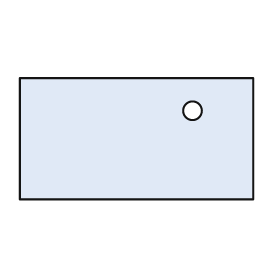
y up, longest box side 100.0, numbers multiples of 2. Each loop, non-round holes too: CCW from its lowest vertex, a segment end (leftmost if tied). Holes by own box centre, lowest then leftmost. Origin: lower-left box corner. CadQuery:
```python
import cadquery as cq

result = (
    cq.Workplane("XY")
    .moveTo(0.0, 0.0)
    .lineTo(100.0, 0.0)
    .lineTo(100.0, 52.0)
    .lineTo(0.0, 52.0)
    .close()
    .moveTo(74.0, 38.0)
    .circle(4.0)
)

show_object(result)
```